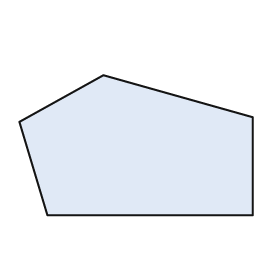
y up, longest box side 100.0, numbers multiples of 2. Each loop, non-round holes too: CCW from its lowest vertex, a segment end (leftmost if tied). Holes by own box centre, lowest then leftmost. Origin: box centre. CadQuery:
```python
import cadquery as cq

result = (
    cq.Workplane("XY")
    .moveTo(-38.0, -30.0)
    .lineTo(50.0, -30.0)
    .lineTo(50.0, 12.0)
    .lineTo(-14.0, 30.0)
    .lineTo(-50.0, 10.0)
    .close()
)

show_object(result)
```